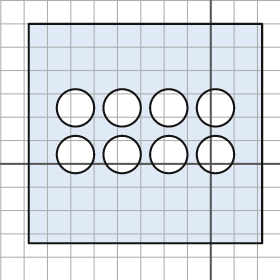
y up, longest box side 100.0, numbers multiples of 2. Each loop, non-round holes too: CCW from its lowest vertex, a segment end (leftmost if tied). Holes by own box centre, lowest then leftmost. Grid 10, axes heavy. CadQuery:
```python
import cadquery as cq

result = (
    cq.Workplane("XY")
    .moveTo(-78.0, -34.0)
    .lineTo(22.0, -34.0)
    .lineTo(22.0, 60.0)
    .lineTo(-78.0, 60.0)
    .close()
    .moveTo(-58.0, 4.0)
    .circle(8.0)
    .moveTo(-38.0, 4.0)
    .circle(8.0)
    .moveTo(-18.0, 4.0)
    .circle(8.0)
    .moveTo(2.0, 4.0)
    .circle(8.0)
    .moveTo(-58.0, 24.0)
    .circle(8.0)
    .moveTo(-38.0, 24.0)
    .circle(8.0)
    .moveTo(-18.0, 24.0)
    .circle(8.0)
    .moveTo(2.0, 24.0)
    .circle(8.0)
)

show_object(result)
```